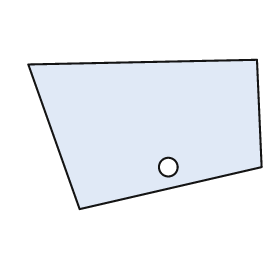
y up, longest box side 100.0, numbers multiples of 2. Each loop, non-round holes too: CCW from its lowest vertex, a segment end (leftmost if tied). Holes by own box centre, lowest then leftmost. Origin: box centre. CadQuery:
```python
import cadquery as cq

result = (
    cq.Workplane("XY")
    .moveTo(-28.0, -32.0)
    .lineTo(50.0, -14.0)
    .lineTo(48.0, 32.0)
    .lineTo(-50.0, 30.0)
    .close()
    .moveTo(10.0, -14.0)
    .circle(4.0)
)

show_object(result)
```